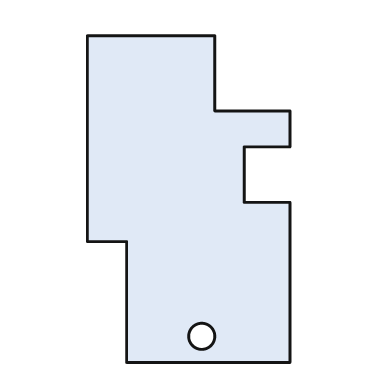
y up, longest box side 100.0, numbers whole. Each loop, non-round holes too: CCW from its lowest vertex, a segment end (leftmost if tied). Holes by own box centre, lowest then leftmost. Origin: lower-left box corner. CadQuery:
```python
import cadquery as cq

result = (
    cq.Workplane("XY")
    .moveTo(12.0, 0.0)
    .lineTo(62.0, 0.0)
    .lineTo(62.0, 49.0)
    .lineTo(48.0, 49.0)
    .lineTo(48.0, 66.0)
    .lineTo(62.0, 66.0)
    .lineTo(62.0, 77.0)
    .lineTo(39.0, 77.0)
    .lineTo(39.0, 100.0)
    .lineTo(0.0, 100.0)
    .lineTo(0.0, 37.0)
    .lineTo(12.0, 37.0)
    .close()
    .moveTo(35.0, 8.0)
    .circle(4.0)
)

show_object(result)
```